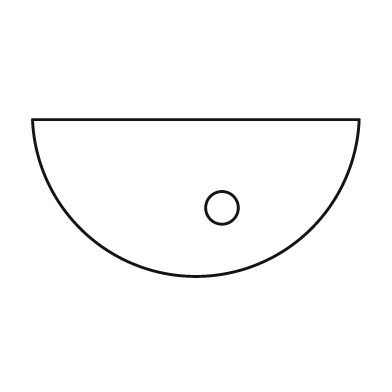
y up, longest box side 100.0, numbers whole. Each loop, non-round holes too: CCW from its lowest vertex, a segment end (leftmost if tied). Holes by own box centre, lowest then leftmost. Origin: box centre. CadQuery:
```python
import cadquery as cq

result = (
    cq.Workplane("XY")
    .moveTo(-50.0, 24.0)
    .threePointArc((0.0, -24.0), (50.0, 24.0))
    .close()
    .moveTo(8.0, -3.0)
    .circle(5.0)
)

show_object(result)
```